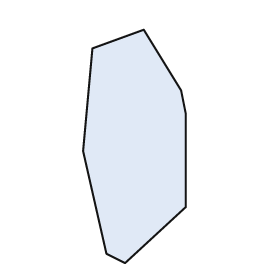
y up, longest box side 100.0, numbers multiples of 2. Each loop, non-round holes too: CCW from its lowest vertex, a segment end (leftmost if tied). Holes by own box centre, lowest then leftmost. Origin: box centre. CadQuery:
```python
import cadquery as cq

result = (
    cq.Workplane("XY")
    .moveTo(-4.0, -50.0)
    .lineTo(22.0, -26.0)
    .lineTo(22.0, 14.0)
    .lineTo(20.0, 24.0)
    .lineTo(4.0, 50.0)
    .lineTo(-18.0, 42.0)
    .lineTo(-22.0, -2.0)
    .lineTo(-12.0, -46.0)
    .close()
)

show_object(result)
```